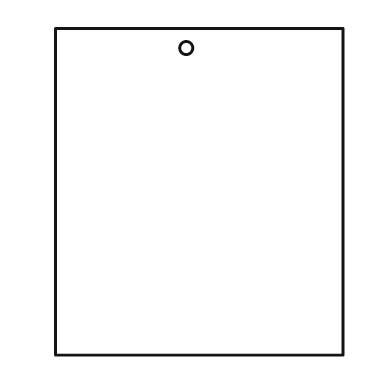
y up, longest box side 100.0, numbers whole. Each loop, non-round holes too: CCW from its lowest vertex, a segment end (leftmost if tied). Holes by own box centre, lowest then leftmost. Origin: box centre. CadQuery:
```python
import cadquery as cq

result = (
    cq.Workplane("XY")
    .moveTo(-44.0, -50.0)
    .lineTo(44.0, -50.0)
    .lineTo(44.0, 50.0)
    .lineTo(-44.0, 50.0)
    .close()
    .moveTo(-4.0, 44.0)
    .circle(2.0)
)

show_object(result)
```